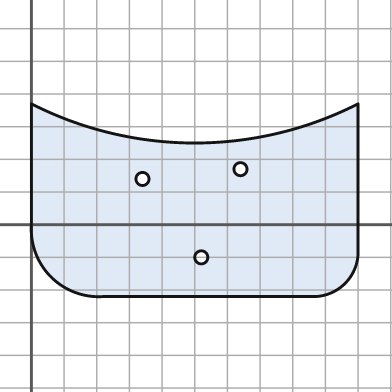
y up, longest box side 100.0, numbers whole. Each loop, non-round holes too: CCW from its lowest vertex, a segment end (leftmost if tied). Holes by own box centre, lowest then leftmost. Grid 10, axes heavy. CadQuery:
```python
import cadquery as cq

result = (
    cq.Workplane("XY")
    .moveTo(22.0, -22.0)
    .lineTo(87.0, -22.0)
    .threePointArc((96.0, -18.0), (100.0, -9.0))
    .lineTo(100.0, 37.0)
    .threePointArc((50.0, 25.0), (0.0, 37.0))
    .lineTo(0.0, 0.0)
    .threePointArc((6.0, -16.0), (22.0, -22.0))
    .close()
    .moveTo(52.0, -10.0)
    .circle(2.0)
    .moveTo(34.0, 14.0)
    .circle(2.0)
    .moveTo(64.0, 17.0)
    .circle(2.0)
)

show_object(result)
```